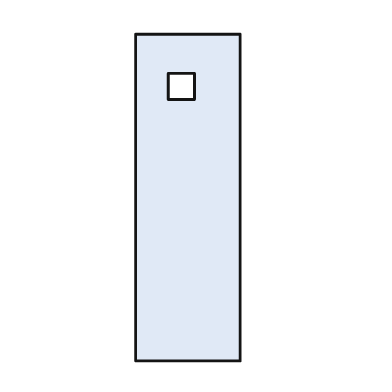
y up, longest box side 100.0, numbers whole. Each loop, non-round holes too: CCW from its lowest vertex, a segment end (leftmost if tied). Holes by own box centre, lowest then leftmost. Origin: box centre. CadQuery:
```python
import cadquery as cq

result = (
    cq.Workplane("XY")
    .moveTo(-16.0, -50.0)
    .lineTo(16.0, -50.0)
    .lineTo(16.0, 50.0)
    .lineTo(-16.0, 50.0)
    .close()
    .moveTo(-6.0, 30.0)
    .lineTo(2.0, 30.0)
    .lineTo(2.0, 38.0)
    .lineTo(-6.0, 38.0)
    .close()
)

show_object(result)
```